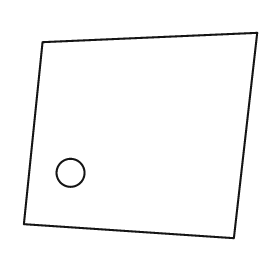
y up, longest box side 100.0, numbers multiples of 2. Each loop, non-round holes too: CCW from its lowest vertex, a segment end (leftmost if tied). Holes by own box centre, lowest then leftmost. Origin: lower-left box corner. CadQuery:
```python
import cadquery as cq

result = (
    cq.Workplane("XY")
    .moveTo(90.0, 0.0)
    .lineTo(100.0, 88.0)
    .lineTo(8.0, 84.0)
    .lineTo(0.0, 6.0)
    .close()
    .moveTo(20.0, 28.0)
    .circle(6.0)
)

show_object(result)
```